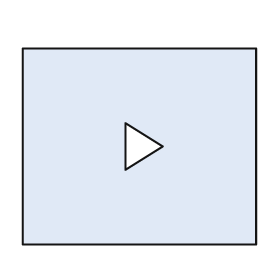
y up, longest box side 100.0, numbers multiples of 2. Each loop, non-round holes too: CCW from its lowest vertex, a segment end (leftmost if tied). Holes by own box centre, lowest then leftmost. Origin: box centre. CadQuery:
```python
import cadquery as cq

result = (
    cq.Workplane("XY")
    .moveTo(-50.0, -42.0)
    .lineTo(50.0, -42.0)
    .lineTo(50.0, 42.0)
    .lineTo(-50.0, 42.0)
    .close()
    .moveTo(-6.0, -10.0)
    .lineTo(10.0, 0.0)
    .lineTo(-6.0, 10.0)
    .close()
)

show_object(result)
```